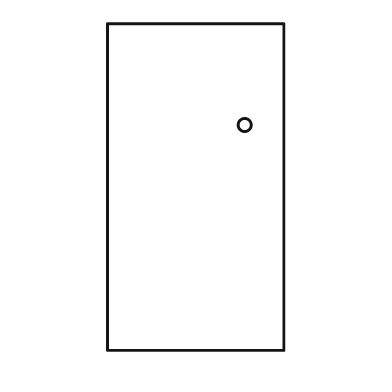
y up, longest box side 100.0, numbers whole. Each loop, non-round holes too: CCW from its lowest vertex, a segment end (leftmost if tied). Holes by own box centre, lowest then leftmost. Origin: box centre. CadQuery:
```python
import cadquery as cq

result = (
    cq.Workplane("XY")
    .moveTo(-27.0, -50.0)
    .lineTo(27.0, -50.0)
    .lineTo(27.0, 50.0)
    .lineTo(-27.0, 50.0)
    .close()
    .moveTo(15.0, 19.0)
    .circle(2.0)
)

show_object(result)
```